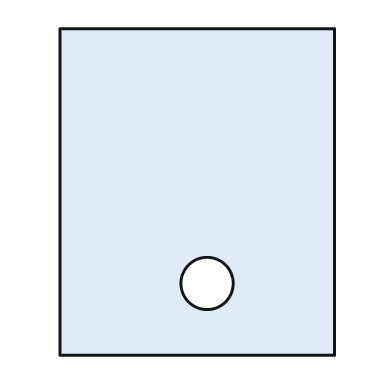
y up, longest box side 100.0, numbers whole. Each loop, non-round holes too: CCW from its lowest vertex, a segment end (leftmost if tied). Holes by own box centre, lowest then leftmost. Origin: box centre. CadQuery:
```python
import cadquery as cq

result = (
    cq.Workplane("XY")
    .moveTo(-42.0, -50.0)
    .lineTo(42.0, -50.0)
    .lineTo(42.0, 50.0)
    .lineTo(-42.0, 50.0)
    .close()
    .moveTo(3.0, -28.0)
    .circle(8.0)
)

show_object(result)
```